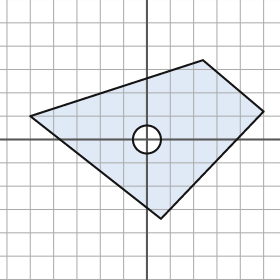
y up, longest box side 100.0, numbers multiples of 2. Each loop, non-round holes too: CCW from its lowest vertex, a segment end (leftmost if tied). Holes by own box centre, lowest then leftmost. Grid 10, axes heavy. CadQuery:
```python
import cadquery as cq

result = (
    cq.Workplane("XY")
    .moveTo(6.0, -34.0)
    .lineTo(50.0, 12.0)
    .lineTo(24.0, 34.0)
    .lineTo(-50.0, 10.0)
    .close()
    .moveTo(0.0, 0.0)
    .circle(6.0)
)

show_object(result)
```